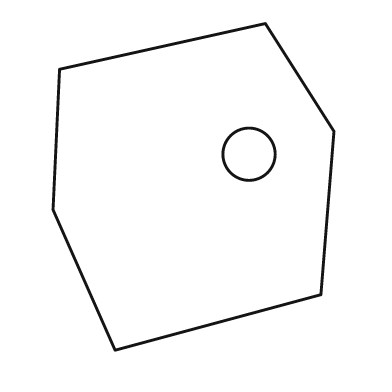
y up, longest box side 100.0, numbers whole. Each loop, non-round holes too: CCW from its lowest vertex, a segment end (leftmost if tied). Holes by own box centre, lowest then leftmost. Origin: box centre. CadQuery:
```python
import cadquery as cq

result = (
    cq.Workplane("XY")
    .moveTo(-24.0, -50.0)
    .lineTo(39.0, -33.0)
    .lineTo(43.0, 17.0)
    .lineTo(22.0, 50.0)
    .lineTo(-41.0, 36.0)
    .lineTo(-43.0, -7.0)
    .close()
    .moveTo(17.0, 10.0)
    .circle(8.0)
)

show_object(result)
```